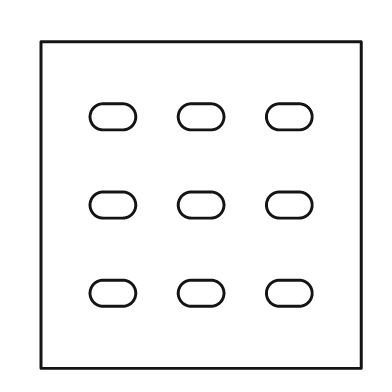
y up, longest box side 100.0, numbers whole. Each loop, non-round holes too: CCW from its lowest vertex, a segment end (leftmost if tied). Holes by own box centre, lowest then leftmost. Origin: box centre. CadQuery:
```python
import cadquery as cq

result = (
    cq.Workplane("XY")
    .moveTo(-49.0, -50.0)
    .lineTo(49.0, -50.0)
    .lineTo(49.0, 50.0)
    .lineTo(-49.0, 50.0)
    .close()
    .moveTo(-30.0, -31.0)
    .lineTo(-24.0, -31.0)
    .threePointArc((-20.0, -27.0), (-24.0, -23.0))
    .lineTo(-30.0, -23.0)
    .threePointArc((-34.0, -27.0), (-30.0, -31.0))
    .close()
    .moveTo(-3.0, -31.0)
    .lineTo(3.0, -31.0)
    .threePointArc((7.0, -27.0), (3.0, -23.0))
    .lineTo(-3.0, -23.0)
    .threePointArc((-7.0, -27.0), (-3.0, -31.0))
    .close()
    .moveTo(24.0, -31.0)
    .lineTo(30.0, -31.0)
    .threePointArc((34.0, -27.0), (30.0, -23.0))
    .lineTo(24.0, -23.0)
    .threePointArc((20.0, -27.0), (24.0, -31.0))
    .close()
    .moveTo(-30.0, -4.0)
    .lineTo(-24.0, -4.0)
    .threePointArc((-20.0, 0.0), (-24.0, 4.0))
    .lineTo(-30.0, 4.0)
    .threePointArc((-34.0, 0.0), (-30.0, -4.0))
    .close()
    .moveTo(-3.0, -4.0)
    .lineTo(3.0, -4.0)
    .threePointArc((7.0, 0.0), (3.0, 4.0))
    .lineTo(-3.0, 4.0)
    .threePointArc((-7.0, 0.0), (-3.0, -4.0))
    .close()
    .moveTo(24.0, -4.0)
    .lineTo(30.0, -4.0)
    .threePointArc((34.0, 0.0), (30.0, 4.0))
    .lineTo(24.0, 4.0)
    .threePointArc((20.0, 0.0), (24.0, -4.0))
    .close()
    .moveTo(-30.0, 23.0)
    .lineTo(-24.0, 23.0)
    .threePointArc((-20.0, 27.0), (-24.0, 31.0))
    .lineTo(-30.0, 31.0)
    .threePointArc((-34.0, 27.0), (-30.0, 23.0))
    .close()
    .moveTo(-3.0, 23.0)
    .lineTo(3.0, 23.0)
    .threePointArc((7.0, 27.0), (3.0, 31.0))
    .lineTo(-3.0, 31.0)
    .threePointArc((-7.0, 27.0), (-3.0, 23.0))
    .close()
    .moveTo(24.0, 23.0)
    .lineTo(30.0, 23.0)
    .threePointArc((34.0, 27.0), (30.0, 31.0))
    .lineTo(24.0, 31.0)
    .threePointArc((20.0, 27.0), (24.0, 23.0))
    .close()
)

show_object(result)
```